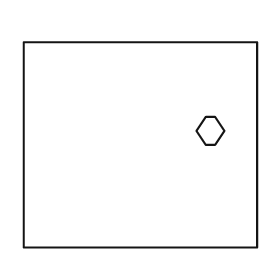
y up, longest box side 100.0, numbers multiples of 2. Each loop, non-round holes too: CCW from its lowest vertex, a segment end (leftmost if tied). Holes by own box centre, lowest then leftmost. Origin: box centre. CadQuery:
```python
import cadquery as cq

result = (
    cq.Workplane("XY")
    .moveTo(-50.0, -44.0)
    .lineTo(50.0, -44.0)
    .lineTo(50.0, 44.0)
    .lineTo(-50.0, 44.0)
    .close()
    .moveTo(28.0, 0.0)
    .lineTo(32.0, 0.0)
    .lineTo(36.0, 6.0)
    .lineTo(32.0, 12.0)
    .lineTo(28.0, 12.0)
    .lineTo(24.0, 6.0)
    .close()
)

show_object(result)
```